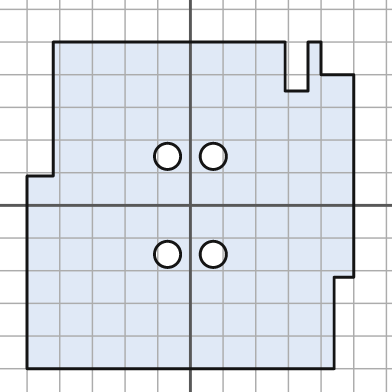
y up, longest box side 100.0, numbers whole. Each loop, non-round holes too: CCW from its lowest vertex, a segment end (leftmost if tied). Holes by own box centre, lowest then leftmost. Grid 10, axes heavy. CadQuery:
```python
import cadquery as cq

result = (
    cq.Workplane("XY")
    .moveTo(-50.0, -50.0)
    .lineTo(44.0, -50.0)
    .lineTo(44.0, -22.0)
    .lineTo(50.0, -22.0)
    .lineTo(50.0, 40.0)
    .lineTo(40.0, 40.0)
    .lineTo(40.0, 50.0)
    .lineTo(36.0, 50.0)
    .lineTo(36.0, 35.0)
    .lineTo(29.0, 35.0)
    .lineTo(29.0, 50.0)
    .lineTo(-42.0, 50.0)
    .lineTo(-42.0, 9.0)
    .lineTo(-50.0, 9.0)
    .close()
    .moveTo(-7.0, -15.0)
    .circle(4.0)
    .moveTo(7.0, -15.0)
    .circle(4.0)
    .moveTo(-7.0, 15.0)
    .circle(4.0)
    .moveTo(7.0, 15.0)
    .circle(4.0)
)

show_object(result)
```